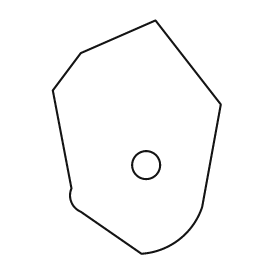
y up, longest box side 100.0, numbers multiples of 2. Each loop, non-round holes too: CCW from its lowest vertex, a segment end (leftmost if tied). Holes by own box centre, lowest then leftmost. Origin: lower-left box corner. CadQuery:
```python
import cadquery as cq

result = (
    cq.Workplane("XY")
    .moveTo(38.0, 0.0)
    .threePointArc((54.0, 6.0), (64.0, 20.0))
    .lineTo(72.0, 64.0)
    .lineTo(44.0, 100.0)
    .lineTo(12.0, 86.0)
    .lineTo(0.0, 70.0)
    .lineTo(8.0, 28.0)
    .threePointArc((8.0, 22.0), (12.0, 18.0))
    .close()
    .moveTo(40.0, 38.0)
    .circle(6.0)
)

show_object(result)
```